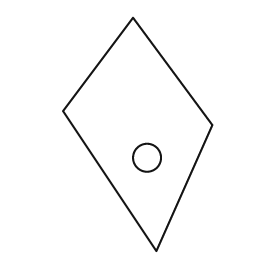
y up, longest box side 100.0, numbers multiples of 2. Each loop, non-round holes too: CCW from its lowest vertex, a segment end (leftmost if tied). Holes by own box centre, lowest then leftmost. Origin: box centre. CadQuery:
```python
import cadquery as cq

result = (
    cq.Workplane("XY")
    .moveTo(8.0, -50.0)
    .lineTo(32.0, 4.0)
    .lineTo(-2.0, 50.0)
    .lineTo(-32.0, 10.0)
    .close()
    .moveTo(4.0, -10.0)
    .circle(6.0)
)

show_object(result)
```